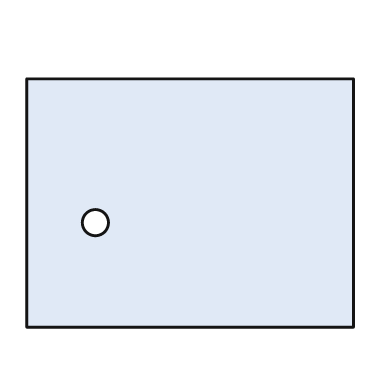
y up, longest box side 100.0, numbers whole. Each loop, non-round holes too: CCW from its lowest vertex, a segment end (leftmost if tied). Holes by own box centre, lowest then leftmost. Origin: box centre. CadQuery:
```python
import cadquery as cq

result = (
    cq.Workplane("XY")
    .moveTo(-50.0, -38.0)
    .lineTo(50.0, -38.0)
    .lineTo(50.0, 38.0)
    .lineTo(-50.0, 38.0)
    .close()
    .moveTo(-29.0, -6.0)
    .circle(4.0)
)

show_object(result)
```